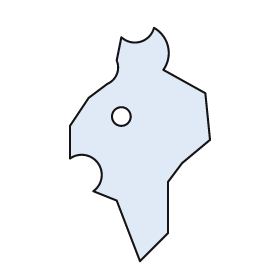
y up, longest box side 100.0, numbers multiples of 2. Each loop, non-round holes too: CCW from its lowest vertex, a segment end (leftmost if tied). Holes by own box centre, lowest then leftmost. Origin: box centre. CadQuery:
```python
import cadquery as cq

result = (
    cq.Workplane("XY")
    .moveTo(0.0, -50.0)
    .lineTo(12.0, -38.0)
    .lineTo(12.0, -16.0)
    .lineTo(18.0, -8.0)
    .lineTo(30.0, 2.0)
    .lineTo(28.0, 22.0)
    .lineTo(10.0, 32.0)
    .threePointArc((12.0, 42.0), (6.0, 50.0))
    .threePointArc((0.0, 44.0), (-8.0, 46.0))
    .lineTo(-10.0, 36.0)
    .threePointArc((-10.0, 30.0), (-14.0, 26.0))
    .lineTo(-22.0, 20.0)
    .lineTo(-30.0, 8.0)
    .lineTo(-30.0, -6.0)
    .threePointArc((-18.0, -8.0), (-20.0, -20.0))
    .lineTo(-10.0, -24.0)
    .close()
    .moveTo(-8.0, 12.0)
    .circle(4.0)
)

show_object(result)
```